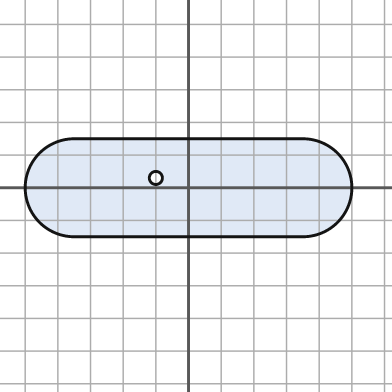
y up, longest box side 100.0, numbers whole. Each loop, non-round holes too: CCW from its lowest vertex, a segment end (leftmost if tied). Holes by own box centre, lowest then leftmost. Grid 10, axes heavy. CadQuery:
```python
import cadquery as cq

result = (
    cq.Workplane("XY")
    .moveTo(-35.0, -15.0)
    .lineTo(35.0, -15.0)
    .threePointArc((50.0, 0.0), (35.0, 15.0))
    .lineTo(-35.0, 15.0)
    .threePointArc((-50.0, 0.0), (-35.0, -15.0))
    .close()
    .moveTo(-10.0, 3.0)
    .circle(2.0)
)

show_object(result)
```